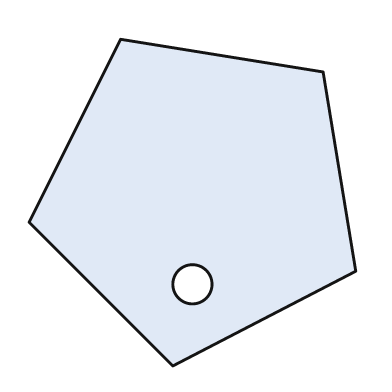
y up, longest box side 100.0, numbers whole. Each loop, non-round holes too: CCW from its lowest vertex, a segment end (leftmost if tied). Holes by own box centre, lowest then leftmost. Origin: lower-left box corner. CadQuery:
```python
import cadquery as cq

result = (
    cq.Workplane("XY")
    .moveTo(44.0, 0.0)
    .lineTo(100.0, 29.0)
    .lineTo(90.0, 90.0)
    .lineTo(28.0, 100.0)
    .lineTo(0.0, 44.0)
    .close()
    .moveTo(50.0, 25.0)
    .circle(6.0)
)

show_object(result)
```